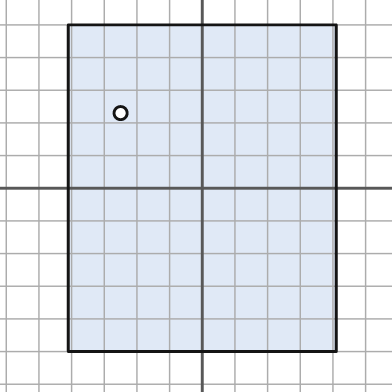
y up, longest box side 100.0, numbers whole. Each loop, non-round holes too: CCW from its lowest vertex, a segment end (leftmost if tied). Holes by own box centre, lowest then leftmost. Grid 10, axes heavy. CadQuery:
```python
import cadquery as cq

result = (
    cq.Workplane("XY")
    .moveTo(-41.0, -50.0)
    .lineTo(41.0, -50.0)
    .lineTo(41.0, 50.0)
    .lineTo(-41.0, 50.0)
    .close()
    .moveTo(-25.0, 23.0)
    .circle(2.0)
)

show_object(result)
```